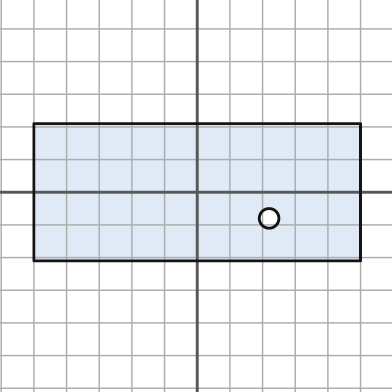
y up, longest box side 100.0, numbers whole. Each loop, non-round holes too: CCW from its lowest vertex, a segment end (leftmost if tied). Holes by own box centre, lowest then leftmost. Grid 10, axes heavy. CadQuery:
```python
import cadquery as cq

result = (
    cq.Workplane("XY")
    .moveTo(-50.0, -21.0)
    .lineTo(50.0, -21.0)
    .lineTo(50.0, 21.0)
    .lineTo(-50.0, 21.0)
    .close()
    .moveTo(22.0, -8.0)
    .circle(3.0)
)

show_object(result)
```